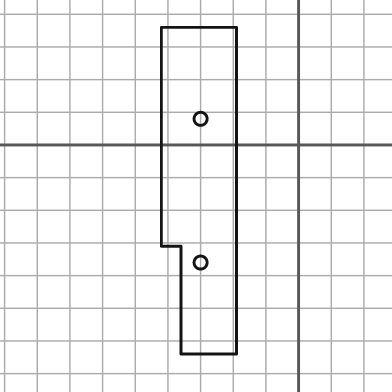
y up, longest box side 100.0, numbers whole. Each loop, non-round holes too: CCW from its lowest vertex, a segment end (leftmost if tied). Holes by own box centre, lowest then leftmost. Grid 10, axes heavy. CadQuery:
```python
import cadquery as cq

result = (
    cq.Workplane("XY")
    .moveTo(-36.0, -64.0)
    .lineTo(-19.0, -64.0)
    .lineTo(-19.0, 36.0)
    .lineTo(-42.0, 36.0)
    .lineTo(-42.0, -31.0)
    .lineTo(-36.0, -31.0)
    .close()
    .moveTo(-30.0, -36.0)
    .circle(2.0)
    .moveTo(-30.0, 8.0)
    .circle(2.0)
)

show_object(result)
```